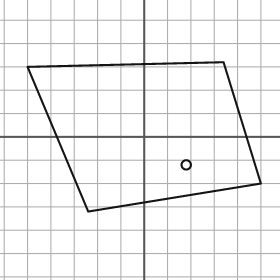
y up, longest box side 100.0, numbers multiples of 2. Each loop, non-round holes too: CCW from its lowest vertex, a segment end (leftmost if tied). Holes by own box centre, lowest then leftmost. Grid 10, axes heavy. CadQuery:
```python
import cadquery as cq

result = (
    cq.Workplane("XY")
    .moveTo(-24.0, -32.0)
    .lineTo(50.0, -20.0)
    .lineTo(34.0, 32.0)
    .lineTo(-50.0, 30.0)
    .close()
    .moveTo(18.0, -12.0)
    .circle(2.0)
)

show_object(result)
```